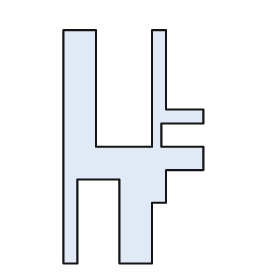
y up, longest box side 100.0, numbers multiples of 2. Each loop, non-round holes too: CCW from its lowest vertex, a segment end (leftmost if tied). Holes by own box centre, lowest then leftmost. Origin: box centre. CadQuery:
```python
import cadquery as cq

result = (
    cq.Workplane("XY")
    .moveTo(-30.0, -50.0)
    .lineTo(-24.0, -50.0)
    .lineTo(-24.0, -14.0)
    .lineTo(-6.0, -14.0)
    .lineTo(-6.0, -50.0)
    .lineTo(8.0, -50.0)
    .lineTo(8.0, -24.0)
    .lineTo(14.0, -24.0)
    .lineTo(14.0, -10.0)
    .lineTo(30.0, -10.0)
    .lineTo(30.0, 0.0)
    .lineTo(12.0, 0.0)
    .lineTo(12.0, 10.0)
    .lineTo(30.0, 10.0)
    .lineTo(30.0, 16.0)
    .lineTo(14.0, 16.0)
    .lineTo(14.0, 50.0)
    .lineTo(8.0, 50.0)
    .lineTo(8.0, 0.0)
    .lineTo(-16.0, 0.0)
    .lineTo(-16.0, 50.0)
    .lineTo(-30.0, 50.0)
    .close()
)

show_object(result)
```